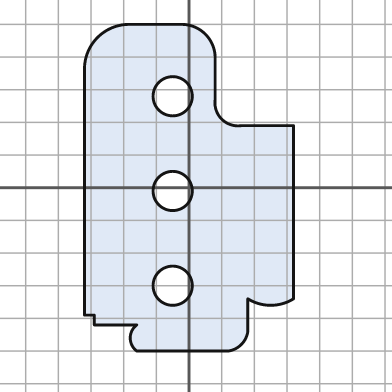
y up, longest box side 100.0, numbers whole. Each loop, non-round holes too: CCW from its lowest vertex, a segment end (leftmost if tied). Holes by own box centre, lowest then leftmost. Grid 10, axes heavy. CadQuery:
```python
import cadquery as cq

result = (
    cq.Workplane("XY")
    .moveTo(-16.0, -50.0)
    .lineTo(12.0, -50.0)
    .threePointArc((16.0, -48.0), (18.0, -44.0))
    .lineTo(18.0, -34.0)
    .threePointArc((25.0, -36.0), (32.0, -34.0))
    .lineTo(32.0, 19.0)
    .lineTo(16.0, 19.0)
    .threePointArc((10.0, 21.0), (8.0, 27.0))
    .lineTo(8.0, 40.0)
    .threePointArc((5.0, 47.0), (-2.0, 50.0))
    .lineTo(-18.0, 50.0)
    .threePointArc((-28.0, 46.0), (-32.0, 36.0))
    .lineTo(-32.0, -39.0)
    .lineTo(-29.0, -39.0)
    .lineTo(-29.0, -42.0)
    .lineTo(-16.0, -42.0)
    .threePointArc((-18.0, -46.0), (-16.0, -50.0))
    .close()
    .moveTo(-5.0, -30.0)
    .circle(6.0)
    .moveTo(-5.0, -1.0)
    .circle(6.0)
    .moveTo(-5.0, 28.0)
    .circle(6.0)
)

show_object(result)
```